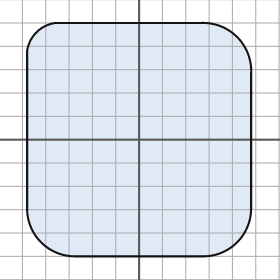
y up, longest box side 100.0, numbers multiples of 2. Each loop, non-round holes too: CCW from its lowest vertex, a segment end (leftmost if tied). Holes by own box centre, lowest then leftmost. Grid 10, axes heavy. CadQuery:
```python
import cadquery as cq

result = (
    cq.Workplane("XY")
    .moveTo(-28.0, -50.0)
    .lineTo(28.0, -50.0)
    .threePointArc((42.0, -44.0), (48.0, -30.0))
    .lineTo(48.0, 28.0)
    .threePointArc((42.0, 44.0), (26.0, 50.0))
    .lineTo(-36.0, 50.0)
    .threePointArc((-44.0, 46.0), (-48.0, 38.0))
    .lineTo(-48.0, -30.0)
    .threePointArc((-42.0, -44.0), (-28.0, -50.0))
    .close()
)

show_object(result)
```